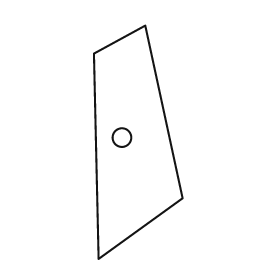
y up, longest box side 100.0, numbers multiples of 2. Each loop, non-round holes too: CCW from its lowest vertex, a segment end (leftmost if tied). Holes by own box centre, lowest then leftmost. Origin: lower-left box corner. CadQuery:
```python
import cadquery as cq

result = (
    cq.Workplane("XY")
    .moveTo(2.0, 0.0)
    .lineTo(38.0, 26.0)
    .lineTo(22.0, 100.0)
    .lineTo(0.0, 88.0)
    .close()
    .moveTo(12.0, 52.0)
    .circle(4.0)
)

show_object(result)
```